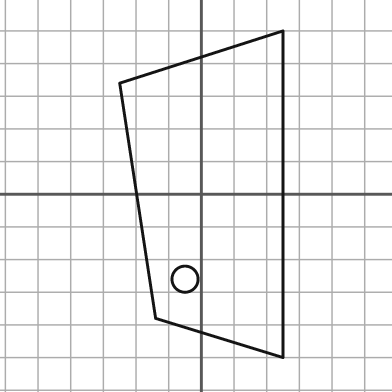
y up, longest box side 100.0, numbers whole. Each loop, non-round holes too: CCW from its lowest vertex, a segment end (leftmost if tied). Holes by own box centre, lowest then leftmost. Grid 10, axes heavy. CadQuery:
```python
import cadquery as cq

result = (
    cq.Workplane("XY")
    .moveTo(25.0, -50.0)
    .lineTo(25.0, 50.0)
    .lineTo(-25.0, 34.0)
    .lineTo(-14.0, -38.0)
    .close()
    .moveTo(-5.0, -26.0)
    .circle(4.0)
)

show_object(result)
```